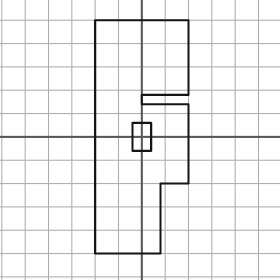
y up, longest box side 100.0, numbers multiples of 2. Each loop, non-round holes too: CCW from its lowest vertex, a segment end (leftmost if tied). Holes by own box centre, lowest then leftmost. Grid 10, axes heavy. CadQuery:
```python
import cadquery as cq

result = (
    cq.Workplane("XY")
    .moveTo(-20.0, -50.0)
    .lineTo(8.0, -50.0)
    .lineTo(8.0, -20.0)
    .lineTo(20.0, -20.0)
    .lineTo(20.0, 14.0)
    .lineTo(0.0, 14.0)
    .lineTo(0.0, 18.0)
    .lineTo(20.0, 18.0)
    .lineTo(20.0, 50.0)
    .lineTo(-20.0, 50.0)
    .close()
    .moveTo(-4.0, -6.0)
    .lineTo(4.0, -6.0)
    .lineTo(4.0, 6.0)
    .lineTo(-4.0, 6.0)
    .close()
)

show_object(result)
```